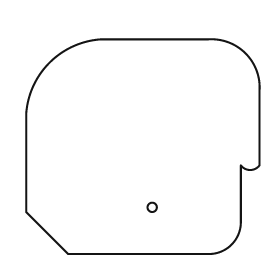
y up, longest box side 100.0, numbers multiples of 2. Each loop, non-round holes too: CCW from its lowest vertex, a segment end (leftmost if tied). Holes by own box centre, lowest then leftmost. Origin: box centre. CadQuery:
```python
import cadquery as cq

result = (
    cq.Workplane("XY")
    .moveTo(-32.0, -46.0)
    .lineTo(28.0, -46.0)
    .threePointArc((38.0, -42.0), (42.0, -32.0))
    .lineTo(42.0, -8.0)
    .threePointArc((46.0, -10.0), (50.0, -8.0))
    .lineTo(50.0, 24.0)
    .threePointArc((44.0, 40.0), (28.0, 46.0))
    .lineTo(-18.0, 46.0)
    .threePointArc((-40.0, 36.0), (-50.0, 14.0))
    .lineTo(-50.0, -28.0)
    .close()
    .moveTo(4.0, -26.0)
    .circle(2.0)
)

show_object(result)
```